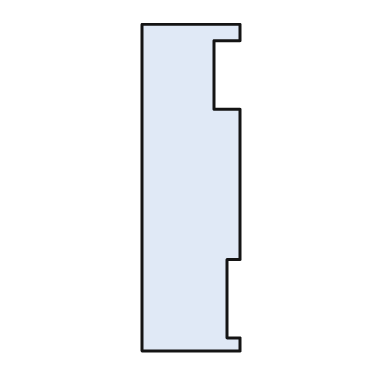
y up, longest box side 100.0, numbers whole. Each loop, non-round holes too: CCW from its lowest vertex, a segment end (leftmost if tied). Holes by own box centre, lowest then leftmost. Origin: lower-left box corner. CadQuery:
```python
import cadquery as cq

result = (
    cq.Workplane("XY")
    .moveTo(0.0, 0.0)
    .lineTo(30.0, 0.0)
    .lineTo(30.0, 4.0)
    .lineTo(26.0, 4.0)
    .lineTo(26.0, 28.0)
    .lineTo(30.0, 28.0)
    .lineTo(30.0, 74.0)
    .lineTo(22.0, 74.0)
    .lineTo(22.0, 95.0)
    .lineTo(30.0, 95.0)
    .lineTo(30.0, 100.0)
    .lineTo(0.0, 100.0)
    .close()
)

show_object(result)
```